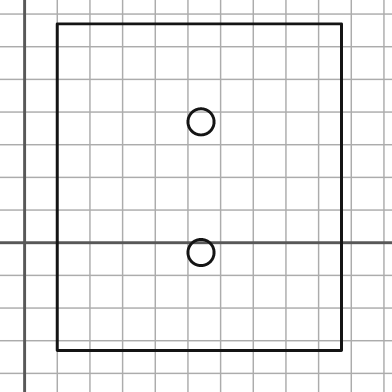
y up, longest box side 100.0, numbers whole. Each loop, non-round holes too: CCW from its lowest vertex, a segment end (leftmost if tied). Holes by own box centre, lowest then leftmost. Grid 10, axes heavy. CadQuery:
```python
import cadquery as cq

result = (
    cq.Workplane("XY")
    .moveTo(10.0, -33.0)
    .lineTo(97.0, -33.0)
    .lineTo(97.0, 67.0)
    .lineTo(10.0, 67.0)
    .close()
    .moveTo(54.0, -3.0)
    .circle(4.0)
    .moveTo(54.0, 37.0)
    .circle(4.0)
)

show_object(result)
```